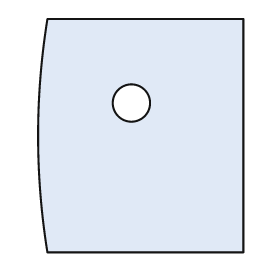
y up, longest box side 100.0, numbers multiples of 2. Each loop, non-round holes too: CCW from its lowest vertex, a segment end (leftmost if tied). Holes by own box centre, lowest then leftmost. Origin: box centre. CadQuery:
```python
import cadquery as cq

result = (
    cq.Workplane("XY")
    .moveTo(-40.0, -50.0)
    .lineTo(44.0, -50.0)
    .lineTo(44.0, 50.0)
    .lineTo(-40.0, 50.0)
    .threePointArc((-44.0, 0.0), (-40.0, -50.0))
    .close()
    .moveTo(-4.0, 14.0)
    .circle(8.0)
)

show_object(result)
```